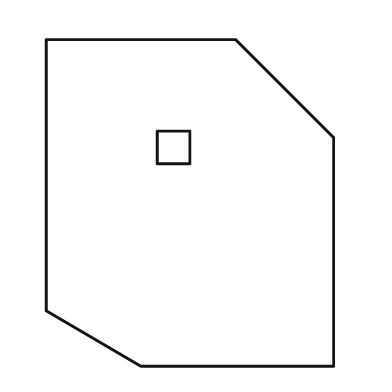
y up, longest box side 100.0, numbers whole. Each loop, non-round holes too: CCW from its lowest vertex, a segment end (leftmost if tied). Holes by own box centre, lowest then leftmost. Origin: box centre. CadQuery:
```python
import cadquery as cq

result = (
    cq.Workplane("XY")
    .moveTo(-15.0, -50.0)
    .lineTo(44.0, -50.0)
    .lineTo(44.0, 20.0)
    .lineTo(14.0, 50.0)
    .lineTo(-44.0, 50.0)
    .lineTo(-44.0, -33.0)
    .close()
    .moveTo(-10.0, 12.0)
    .lineTo(0.0, 12.0)
    .lineTo(0.0, 22.0)
    .lineTo(-10.0, 22.0)
    .close()
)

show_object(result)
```